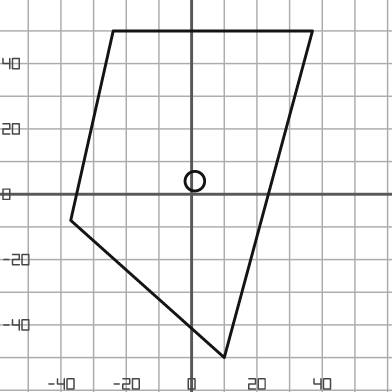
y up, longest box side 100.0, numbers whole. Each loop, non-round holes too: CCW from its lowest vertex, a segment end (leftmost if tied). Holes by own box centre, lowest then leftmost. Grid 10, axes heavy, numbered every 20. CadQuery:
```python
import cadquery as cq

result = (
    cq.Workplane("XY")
    .moveTo(10.0, -50.0)
    .lineTo(37.0, 50.0)
    .lineTo(-24.0, 50.0)
    .lineTo(-37.0, -8.0)
    .close()
    .moveTo(1.0, 4.0)
    .circle(3.0)
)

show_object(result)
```